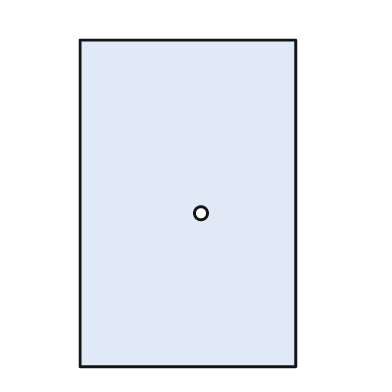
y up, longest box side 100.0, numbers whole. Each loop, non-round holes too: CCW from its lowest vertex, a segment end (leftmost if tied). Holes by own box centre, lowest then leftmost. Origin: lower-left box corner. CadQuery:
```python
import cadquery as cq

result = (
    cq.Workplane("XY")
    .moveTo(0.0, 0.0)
    .lineTo(66.0, 0.0)
    .lineTo(66.0, 100.0)
    .lineTo(0.0, 100.0)
    .close()
    .moveTo(37.0, 47.0)
    .circle(2.0)
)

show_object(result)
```